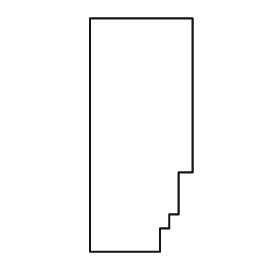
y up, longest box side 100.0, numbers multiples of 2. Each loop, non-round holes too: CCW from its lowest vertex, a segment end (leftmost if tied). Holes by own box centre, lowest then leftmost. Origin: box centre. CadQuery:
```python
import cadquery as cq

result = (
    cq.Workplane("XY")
    .moveTo(-22.0, -50.0)
    .lineTo(8.0, -50.0)
    .lineTo(8.0, -40.0)
    .lineTo(12.0, -40.0)
    .lineTo(12.0, -34.0)
    .lineTo(16.0, -34.0)
    .lineTo(16.0, -16.0)
    .lineTo(22.0, -16.0)
    .lineTo(22.0, 50.0)
    .lineTo(-22.0, 50.0)
    .close()
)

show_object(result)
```